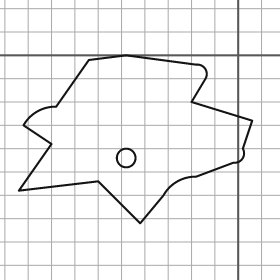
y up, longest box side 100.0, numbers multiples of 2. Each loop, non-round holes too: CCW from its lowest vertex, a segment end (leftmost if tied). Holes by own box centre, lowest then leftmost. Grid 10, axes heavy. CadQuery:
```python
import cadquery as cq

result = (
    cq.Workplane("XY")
    .moveTo(-42.0, -72.0)
    .lineTo(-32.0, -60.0)
    .threePointArc((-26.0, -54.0), (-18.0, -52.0))
    .lineTo(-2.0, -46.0)
    .threePointArc((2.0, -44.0), (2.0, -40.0))
    .lineTo(6.0, -28.0)
    .lineTo(-20.0, -20.0)
    .lineTo(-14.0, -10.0)
    .threePointArc((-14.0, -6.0), (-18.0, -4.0))
    .lineTo(-48.0, 0.0)
    .lineTo(-64.0, -2.0)
    .lineTo(-78.0, -22.0)
    .threePointArc((-86.0, -24.0), (-92.0, -30.0))
    .lineTo(-80.0, -38.0)
    .lineTo(-94.0, -58.0)
    .lineTo(-60.0, -54.0)
    .close()
    .moveTo(-48.0, -44.0)
    .circle(4.0)
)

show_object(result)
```